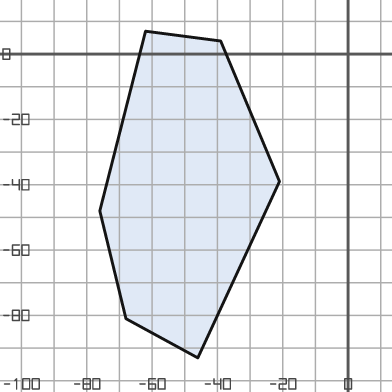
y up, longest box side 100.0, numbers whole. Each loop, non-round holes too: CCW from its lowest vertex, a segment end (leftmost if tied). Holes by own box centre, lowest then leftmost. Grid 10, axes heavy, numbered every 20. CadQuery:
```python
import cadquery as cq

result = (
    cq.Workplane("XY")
    .moveTo(-46.0, -93.0)
    .lineTo(-21.0, -39.0)
    .lineTo(-39.0, 4.0)
    .lineTo(-62.0, 7.0)
    .lineTo(-76.0, -48.0)
    .lineTo(-68.0, -81.0)
    .close()
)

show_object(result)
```